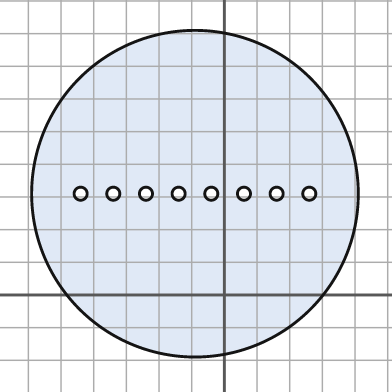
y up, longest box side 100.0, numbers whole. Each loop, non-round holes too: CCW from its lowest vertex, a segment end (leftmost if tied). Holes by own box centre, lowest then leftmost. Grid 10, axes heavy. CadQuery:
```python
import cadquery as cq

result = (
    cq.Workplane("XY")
    .moveTo(-9.0, 31.0)
    .circle(50.0)
    .moveTo(-44.0, 31.0)
    .circle(2.0)
    .moveTo(-34.0, 31.0)
    .circle(2.0)
    .moveTo(-24.0, 31.0)
    .circle(2.0)
    .moveTo(-14.0, 31.0)
    .circle(2.0)
    .moveTo(-4.0, 31.0)
    .circle(2.0)
    .moveTo(6.0, 31.0)
    .circle(2.0)
    .moveTo(16.0, 31.0)
    .circle(2.0)
    .moveTo(26.0, 31.0)
    .circle(2.0)
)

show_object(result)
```